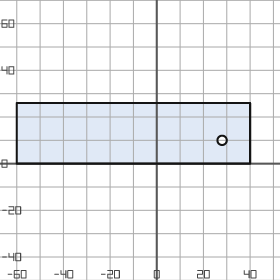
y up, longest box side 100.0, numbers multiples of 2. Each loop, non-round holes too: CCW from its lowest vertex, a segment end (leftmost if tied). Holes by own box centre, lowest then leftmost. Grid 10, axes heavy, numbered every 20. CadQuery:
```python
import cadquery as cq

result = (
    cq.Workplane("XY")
    .moveTo(-60.0, 0.0)
    .lineTo(40.0, 0.0)
    .lineTo(40.0, 26.0)
    .lineTo(-60.0, 26.0)
    .close()
    .moveTo(28.0, 10.0)
    .circle(2.0)
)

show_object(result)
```